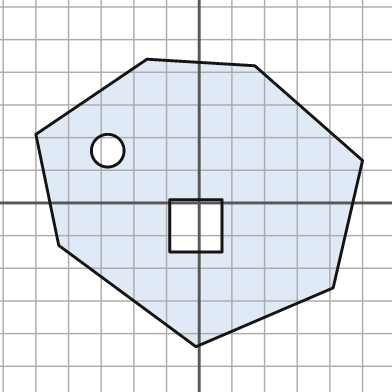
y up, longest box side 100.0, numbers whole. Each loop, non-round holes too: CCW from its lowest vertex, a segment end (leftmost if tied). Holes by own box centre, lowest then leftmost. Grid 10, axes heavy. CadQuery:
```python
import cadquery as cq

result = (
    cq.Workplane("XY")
    .moveTo(-1.0, -44.0)
    .lineTo(41.0, -26.0)
    .lineTo(50.0, 13.0)
    .lineTo(17.0, 42.0)
    .lineTo(-16.0, 44.0)
    .lineTo(-50.0, 21.0)
    .lineTo(-43.0, -13.0)
    .close()
    .moveTo(-9.0, -15.0)
    .lineTo(7.0, -15.0)
    .lineTo(7.0, 1.0)
    .lineTo(-9.0, 1.0)
    .close()
    .moveTo(-28.0, 16.0)
    .circle(5.0)
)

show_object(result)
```